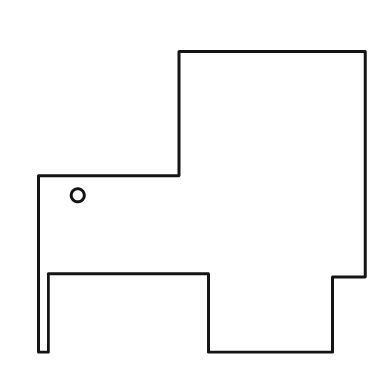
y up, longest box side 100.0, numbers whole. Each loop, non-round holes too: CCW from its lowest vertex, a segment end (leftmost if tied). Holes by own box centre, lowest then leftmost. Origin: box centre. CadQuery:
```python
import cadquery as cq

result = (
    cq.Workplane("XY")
    .moveTo(-50.0, -46.0)
    .lineTo(-47.0, -46.0)
    .lineTo(-47.0, -22.0)
    .lineTo(2.0, -22.0)
    .lineTo(2.0, -46.0)
    .lineTo(40.0, -46.0)
    .lineTo(40.0, -23.0)
    .lineTo(50.0, -23.0)
    .lineTo(50.0, 46.0)
    .lineTo(-7.0, 46.0)
    .lineTo(-7.0, 8.0)
    .lineTo(-50.0, 8.0)
    .close()
    .moveTo(-38.0, 2.0)
    .circle(2.0)
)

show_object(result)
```